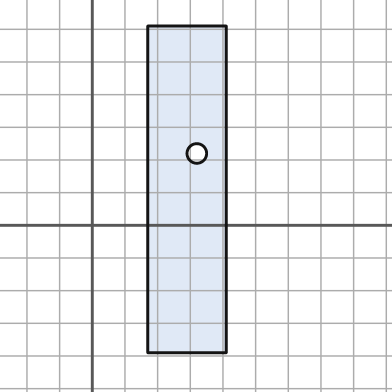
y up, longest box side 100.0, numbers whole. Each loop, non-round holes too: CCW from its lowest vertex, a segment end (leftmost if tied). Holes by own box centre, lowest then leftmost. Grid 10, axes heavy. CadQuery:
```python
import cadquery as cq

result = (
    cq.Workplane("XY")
    .moveTo(17.0, -39.0)
    .lineTo(41.0, -39.0)
    .lineTo(41.0, 61.0)
    .lineTo(17.0, 61.0)
    .close()
    .moveTo(32.0, 22.0)
    .circle(3.0)
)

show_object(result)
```